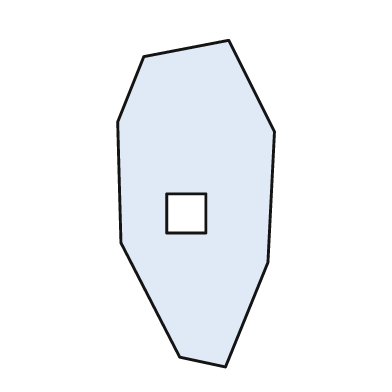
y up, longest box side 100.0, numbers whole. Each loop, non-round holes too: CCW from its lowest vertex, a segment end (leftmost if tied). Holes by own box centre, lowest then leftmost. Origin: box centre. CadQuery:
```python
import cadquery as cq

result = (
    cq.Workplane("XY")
    .moveTo(9.0, -50.0)
    .lineTo(22.0, -18.0)
    .lineTo(24.0, 22.0)
    .lineTo(10.0, 50.0)
    .lineTo(-16.0, 45.0)
    .lineTo(-24.0, 25.0)
    .lineTo(-23.0, -12.0)
    .lineTo(-5.0, -47.0)
    .close()
    .moveTo(-9.0, -9.0)
    .lineTo(3.0, -9.0)
    .lineTo(3.0, 3.0)
    .lineTo(-9.0, 3.0)
    .close()
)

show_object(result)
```